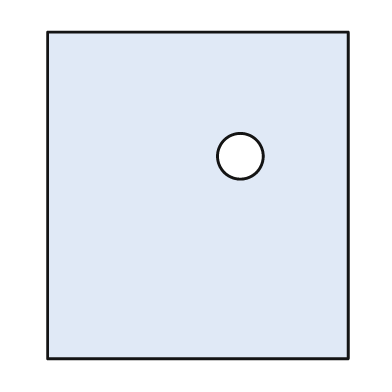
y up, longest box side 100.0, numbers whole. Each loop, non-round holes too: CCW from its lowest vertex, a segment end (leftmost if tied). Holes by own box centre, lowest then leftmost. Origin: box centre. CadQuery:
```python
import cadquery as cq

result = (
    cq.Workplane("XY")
    .moveTo(-46.0, -50.0)
    .lineTo(46.0, -50.0)
    .lineTo(46.0, 50.0)
    .lineTo(-46.0, 50.0)
    .close()
    .moveTo(13.0, 12.0)
    .circle(7.0)
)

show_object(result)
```